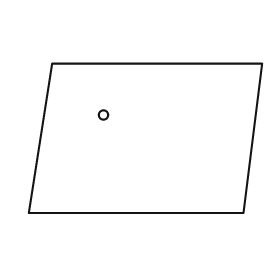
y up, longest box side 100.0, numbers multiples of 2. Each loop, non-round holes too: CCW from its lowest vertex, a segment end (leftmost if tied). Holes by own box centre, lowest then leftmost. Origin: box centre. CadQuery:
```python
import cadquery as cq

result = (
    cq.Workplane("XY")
    .moveTo(-50.0, -32.0)
    .lineTo(42.0, -32.0)
    .lineTo(50.0, 32.0)
    .lineTo(-40.0, 32.0)
    .close()
    .moveTo(-18.0, 10.0)
    .circle(2.0)
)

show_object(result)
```